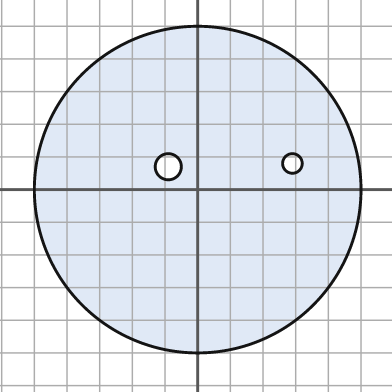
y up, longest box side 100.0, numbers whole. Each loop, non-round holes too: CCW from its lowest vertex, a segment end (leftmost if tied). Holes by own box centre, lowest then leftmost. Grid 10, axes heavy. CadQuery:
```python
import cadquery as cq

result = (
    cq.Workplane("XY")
    .moveTo(0.0, 0.0)
    .circle(50.0)
    .moveTo(-9.0, 7.0)
    .circle(4.0)
    .moveTo(29.0, 8.0)
    .circle(3.0)
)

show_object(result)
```